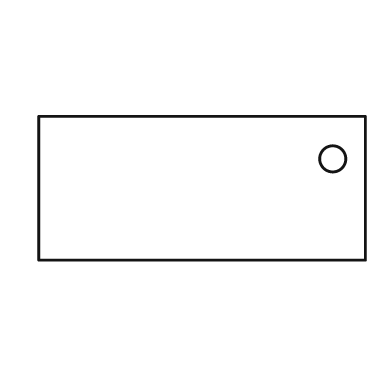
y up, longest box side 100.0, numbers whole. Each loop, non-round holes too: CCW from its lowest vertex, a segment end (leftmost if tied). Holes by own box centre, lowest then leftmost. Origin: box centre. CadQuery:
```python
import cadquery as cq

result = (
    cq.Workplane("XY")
    .moveTo(-50.0, -22.0)
    .lineTo(50.0, -22.0)
    .lineTo(50.0, 22.0)
    .lineTo(-50.0, 22.0)
    .close()
    .moveTo(40.0, 9.0)
    .circle(4.0)
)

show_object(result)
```